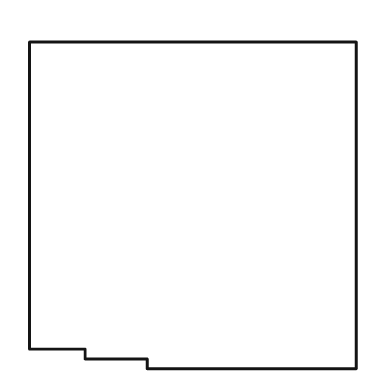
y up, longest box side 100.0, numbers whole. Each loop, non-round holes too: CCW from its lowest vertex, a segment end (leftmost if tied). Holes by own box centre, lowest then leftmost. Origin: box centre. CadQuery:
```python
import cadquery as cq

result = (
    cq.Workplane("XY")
    .moveTo(-14.0, -50.0)
    .lineTo(50.0, -50.0)
    .lineTo(50.0, 50.0)
    .lineTo(-50.0, 50.0)
    .lineTo(-50.0, -44.0)
    .lineTo(-33.0, -44.0)
    .lineTo(-33.0, -47.0)
    .lineTo(-14.0, -47.0)
    .close()
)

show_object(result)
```